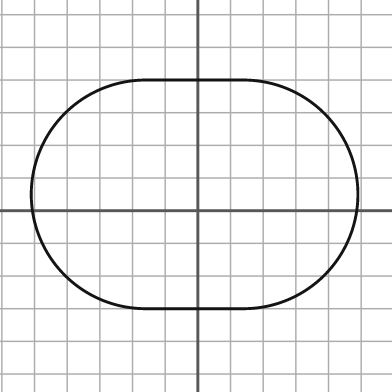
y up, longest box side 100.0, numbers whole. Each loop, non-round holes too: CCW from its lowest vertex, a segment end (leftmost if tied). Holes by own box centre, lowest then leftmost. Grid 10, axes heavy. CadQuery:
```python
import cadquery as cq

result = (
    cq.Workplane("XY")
    .moveTo(-16.0, -30.0)
    .lineTo(14.0, -30.0)
    .threePointArc((49.0, 5.0), (14.0, 40.0))
    .lineTo(-16.0, 40.0)
    .threePointArc((-51.0, 5.0), (-16.0, -30.0))
    .close()
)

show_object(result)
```